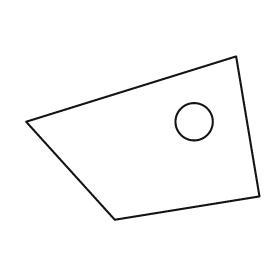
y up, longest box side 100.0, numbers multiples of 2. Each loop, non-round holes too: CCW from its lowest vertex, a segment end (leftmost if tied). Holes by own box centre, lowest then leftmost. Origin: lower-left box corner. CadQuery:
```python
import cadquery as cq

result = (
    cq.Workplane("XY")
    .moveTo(38.0, 0.0)
    .lineTo(100.0, 10.0)
    .lineTo(90.0, 70.0)
    .lineTo(0.0, 42.0)
    .close()
    .moveTo(72.0, 42.0)
    .circle(8.0)
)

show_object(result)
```